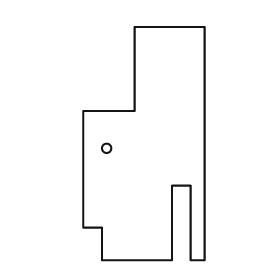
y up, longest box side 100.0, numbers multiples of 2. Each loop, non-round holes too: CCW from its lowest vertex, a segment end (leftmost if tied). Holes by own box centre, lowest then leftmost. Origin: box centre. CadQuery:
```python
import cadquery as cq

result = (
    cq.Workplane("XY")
    .moveTo(-18.0, -50.0)
    .lineTo(12.0, -50.0)
    .lineTo(12.0, -18.0)
    .lineTo(20.0, -18.0)
    .lineTo(20.0, -50.0)
    .lineTo(26.0, -50.0)
    .lineTo(26.0, 50.0)
    .lineTo(-4.0, 50.0)
    .lineTo(-4.0, 14.0)
    .lineTo(-26.0, 14.0)
    .lineTo(-26.0, -36.0)
    .lineTo(-18.0, -36.0)
    .close()
    .moveTo(-16.0, -2.0)
    .circle(2.0)
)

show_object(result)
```